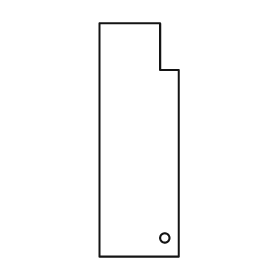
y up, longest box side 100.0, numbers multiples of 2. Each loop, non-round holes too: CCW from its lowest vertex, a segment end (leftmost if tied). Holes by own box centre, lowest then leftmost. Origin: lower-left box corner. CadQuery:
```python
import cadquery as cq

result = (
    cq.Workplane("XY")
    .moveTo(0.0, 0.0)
    .lineTo(34.0, 0.0)
    .lineTo(34.0, 80.0)
    .lineTo(26.0, 80.0)
    .lineTo(26.0, 100.0)
    .lineTo(0.0, 100.0)
    .close()
    .moveTo(28.0, 8.0)
    .circle(2.0)
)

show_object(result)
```